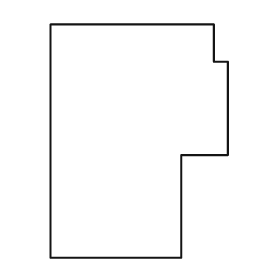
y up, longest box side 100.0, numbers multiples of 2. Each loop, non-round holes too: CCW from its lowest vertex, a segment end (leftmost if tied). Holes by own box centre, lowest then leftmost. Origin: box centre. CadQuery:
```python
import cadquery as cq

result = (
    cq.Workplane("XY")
    .moveTo(-38.0, -50.0)
    .lineTo(18.0, -50.0)
    .lineTo(18.0, -6.0)
    .lineTo(38.0, -6.0)
    .lineTo(38.0, 34.0)
    .lineTo(32.0, 34.0)
    .lineTo(32.0, 50.0)
    .lineTo(-38.0, 50.0)
    .close()
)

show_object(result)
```